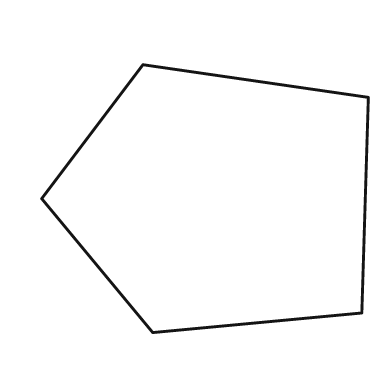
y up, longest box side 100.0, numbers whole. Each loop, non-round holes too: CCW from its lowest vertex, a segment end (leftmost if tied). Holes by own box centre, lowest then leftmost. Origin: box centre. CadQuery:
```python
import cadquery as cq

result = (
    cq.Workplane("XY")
    .moveTo(-16.0, -41.0)
    .lineTo(48.0, -35.0)
    .lineTo(50.0, 31.0)
    .lineTo(-19.0, 41.0)
    .lineTo(-50.0, 0.0)
    .close()
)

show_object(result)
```